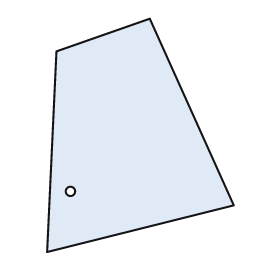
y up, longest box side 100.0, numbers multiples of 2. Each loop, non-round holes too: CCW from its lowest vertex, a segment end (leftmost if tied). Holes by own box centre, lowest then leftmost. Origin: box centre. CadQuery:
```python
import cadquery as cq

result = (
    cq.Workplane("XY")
    .moveTo(-40.0, -50.0)
    .lineTo(40.0, -30.0)
    .lineTo(4.0, 50.0)
    .lineTo(-36.0, 36.0)
    .close()
    .moveTo(-30.0, -24.0)
    .circle(2.0)
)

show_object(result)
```